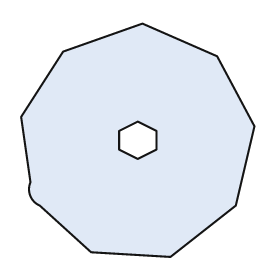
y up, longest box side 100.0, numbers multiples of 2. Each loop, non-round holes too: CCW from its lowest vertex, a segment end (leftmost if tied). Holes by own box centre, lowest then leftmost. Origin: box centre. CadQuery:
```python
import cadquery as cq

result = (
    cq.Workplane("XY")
    .moveTo(14.0, -50.0)
    .lineTo(42.0, -28.0)
    .lineTo(50.0, 6.0)
    .lineTo(34.0, 36.0)
    .lineTo(2.0, 50.0)
    .lineTo(-32.0, 38.0)
    .lineTo(-50.0, 10.0)
    .lineTo(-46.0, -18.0)
    .threePointArc((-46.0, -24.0), (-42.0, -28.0))
    .lineTo(-20.0, -48.0)
    .close()
    .moveTo(0.0, -8.0)
    .lineTo(8.0, -4.0)
    .lineTo(8.0, 4.0)
    .lineTo(0.0, 8.0)
    .lineTo(-8.0, 4.0)
    .lineTo(-8.0, -4.0)
    .close()
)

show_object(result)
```